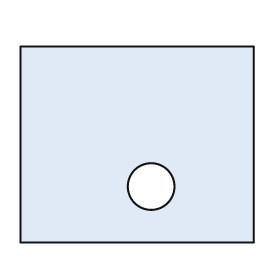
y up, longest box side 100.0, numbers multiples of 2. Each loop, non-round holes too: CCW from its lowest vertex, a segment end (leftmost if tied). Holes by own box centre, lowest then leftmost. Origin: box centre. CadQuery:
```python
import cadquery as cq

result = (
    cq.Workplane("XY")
    .moveTo(-50.0, -42.0)
    .lineTo(50.0, -42.0)
    .lineTo(50.0, 42.0)
    .lineTo(-50.0, 42.0)
    .close()
    .moveTo(6.0, -18.0)
    .circle(10.0)
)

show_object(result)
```